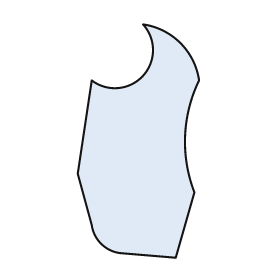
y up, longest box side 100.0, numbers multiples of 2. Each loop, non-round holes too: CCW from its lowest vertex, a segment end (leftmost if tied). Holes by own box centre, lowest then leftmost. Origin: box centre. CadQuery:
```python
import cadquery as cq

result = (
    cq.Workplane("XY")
    .moveTo(16.0, -50.0)
    .lineTo(24.0, -22.0)
    .threePointArc((20.0, 2.0), (26.0, 26.0))
    .threePointArc((18.0, 42.0), (2.0, 50.0))
    .threePointArc((2.0, 28.0), (-20.0, 26.0))
    .lineTo(-26.0, -14.0)
    .lineTo(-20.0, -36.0)
    .threePointArc((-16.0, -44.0), (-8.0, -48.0))
    .close()
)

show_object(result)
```